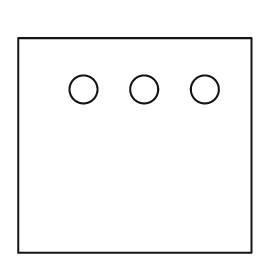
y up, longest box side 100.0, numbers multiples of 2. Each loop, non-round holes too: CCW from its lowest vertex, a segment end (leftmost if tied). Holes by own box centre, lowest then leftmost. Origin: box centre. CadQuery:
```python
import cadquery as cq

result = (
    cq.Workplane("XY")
    .moveTo(-50.0, -46.0)
    .lineTo(50.0, -46.0)
    .lineTo(50.0, 46.0)
    .lineTo(-50.0, 46.0)
    .close()
    .moveTo(-22.0, 24.0)
    .circle(6.0)
    .moveTo(4.0, 24.0)
    .circle(6.0)
    .moveTo(30.0, 24.0)
    .circle(6.0)
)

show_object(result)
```